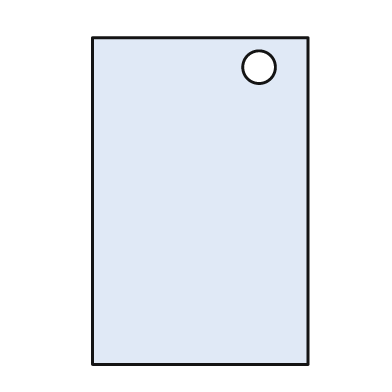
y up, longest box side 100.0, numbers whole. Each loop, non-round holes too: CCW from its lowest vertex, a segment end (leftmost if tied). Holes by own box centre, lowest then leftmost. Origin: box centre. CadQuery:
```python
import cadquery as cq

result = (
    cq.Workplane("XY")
    .moveTo(-33.0, -50.0)
    .lineTo(33.0, -50.0)
    .lineTo(33.0, 50.0)
    .lineTo(-33.0, 50.0)
    .close()
    .moveTo(18.0, 41.0)
    .circle(5.0)
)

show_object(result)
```